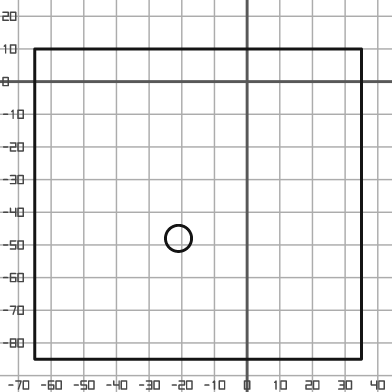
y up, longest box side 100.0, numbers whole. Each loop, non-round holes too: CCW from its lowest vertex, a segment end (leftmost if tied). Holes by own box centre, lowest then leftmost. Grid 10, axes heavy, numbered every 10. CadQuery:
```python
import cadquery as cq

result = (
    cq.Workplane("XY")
    .moveTo(-65.0, -85.0)
    .lineTo(35.0, -85.0)
    .lineTo(35.0, 10.0)
    .lineTo(-65.0, 10.0)
    .close()
    .moveTo(-21.0, -48.0)
    .circle(4.0)
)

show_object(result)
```